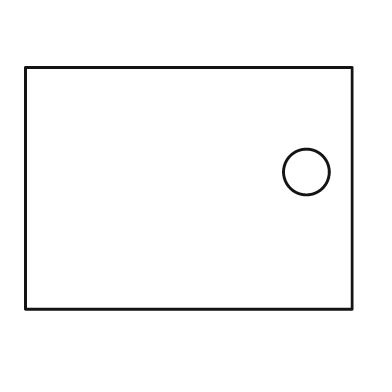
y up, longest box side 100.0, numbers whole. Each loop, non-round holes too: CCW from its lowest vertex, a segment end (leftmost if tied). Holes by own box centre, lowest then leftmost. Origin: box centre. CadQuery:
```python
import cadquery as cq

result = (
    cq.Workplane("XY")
    .moveTo(-50.0, -37.0)
    .lineTo(50.0, -37.0)
    .lineTo(50.0, 37.0)
    .lineTo(-50.0, 37.0)
    .close()
    .moveTo(36.0, 5.0)
    .circle(7.0)
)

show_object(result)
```